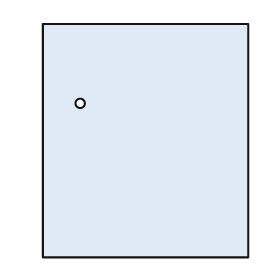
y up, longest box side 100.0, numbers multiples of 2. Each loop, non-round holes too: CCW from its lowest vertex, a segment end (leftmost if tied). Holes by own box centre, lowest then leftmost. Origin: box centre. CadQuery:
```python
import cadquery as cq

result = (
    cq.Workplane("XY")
    .moveTo(-44.0, -50.0)
    .lineTo(44.0, -50.0)
    .lineTo(44.0, 50.0)
    .lineTo(-44.0, 50.0)
    .close()
    .moveTo(-28.0, 16.0)
    .circle(2.0)
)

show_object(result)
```